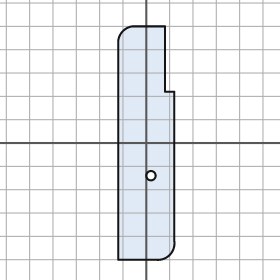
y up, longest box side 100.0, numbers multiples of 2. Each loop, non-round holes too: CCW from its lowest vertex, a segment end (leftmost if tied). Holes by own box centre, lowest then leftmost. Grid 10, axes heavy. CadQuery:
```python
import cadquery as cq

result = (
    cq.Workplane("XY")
    .moveTo(-12.0, -50.0)
    .lineTo(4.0, -50.0)
    .threePointArc((10.0, -48.0), (12.0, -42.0))
    .lineTo(12.0, 22.0)
    .lineTo(8.0, 22.0)
    .lineTo(8.0, 50.0)
    .lineTo(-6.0, 50.0)
    .threePointArc((-10.0, 48.0), (-12.0, 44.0))
    .close()
    .moveTo(2.0, -14.0)
    .circle(2.0)
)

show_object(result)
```